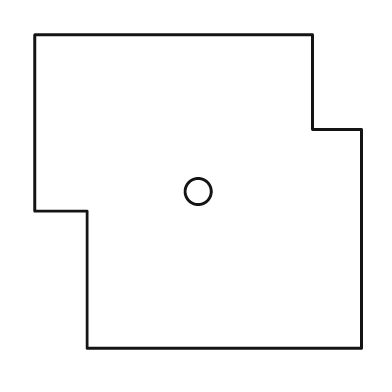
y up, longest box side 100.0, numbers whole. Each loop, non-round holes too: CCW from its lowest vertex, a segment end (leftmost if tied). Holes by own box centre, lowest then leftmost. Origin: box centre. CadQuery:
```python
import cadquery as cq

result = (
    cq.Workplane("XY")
    .moveTo(-34.0, -48.0)
    .lineTo(50.0, -48.0)
    .lineTo(50.0, 19.0)
    .lineTo(35.0, 19.0)
    .lineTo(35.0, 48.0)
    .lineTo(-50.0, 48.0)
    .lineTo(-50.0, -6.0)
    .lineTo(-34.0, -6.0)
    .close()
    .moveTo(0.0, 0.0)
    .circle(4.0)
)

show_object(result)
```